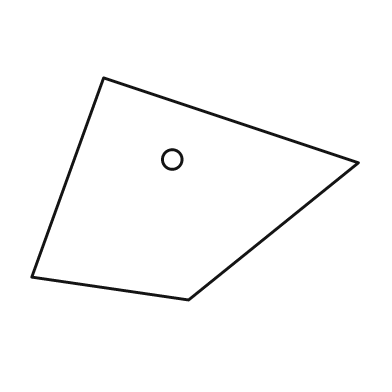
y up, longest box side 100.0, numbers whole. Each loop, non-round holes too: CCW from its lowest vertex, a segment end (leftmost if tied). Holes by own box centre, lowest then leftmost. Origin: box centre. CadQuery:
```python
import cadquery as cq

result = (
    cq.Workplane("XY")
    .moveTo(-2.0, -34.0)
    .lineTo(50.0, 8.0)
    .lineTo(-28.0, 34.0)
    .lineTo(-50.0, -27.0)
    .close()
    .moveTo(-7.0, 9.0)
    .circle(3.0)
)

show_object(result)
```